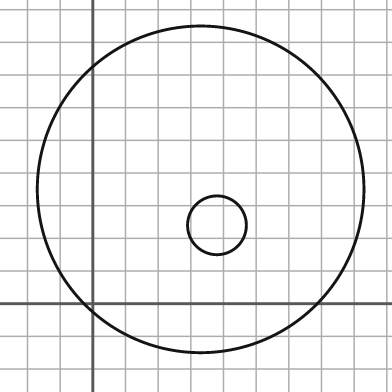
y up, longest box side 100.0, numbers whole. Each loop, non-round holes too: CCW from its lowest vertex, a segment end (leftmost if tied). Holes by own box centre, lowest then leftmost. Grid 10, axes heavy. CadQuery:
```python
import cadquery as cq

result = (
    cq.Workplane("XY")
    .moveTo(33.0, 35.0)
    .circle(50.0)
    .moveTo(38.0, 24.0)
    .circle(9.0)
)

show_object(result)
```